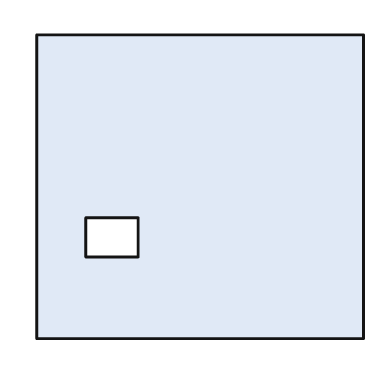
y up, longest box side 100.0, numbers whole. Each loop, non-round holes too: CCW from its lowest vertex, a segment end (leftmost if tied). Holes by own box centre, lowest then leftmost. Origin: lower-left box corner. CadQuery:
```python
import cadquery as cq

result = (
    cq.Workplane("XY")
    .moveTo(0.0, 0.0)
    .lineTo(100.0, 0.0)
    .lineTo(100.0, 93.0)
    .lineTo(0.0, 93.0)
    .close()
    .moveTo(15.0, 25.0)
    .lineTo(31.0, 25.0)
    .lineTo(31.0, 37.0)
    .lineTo(15.0, 37.0)
    .close()
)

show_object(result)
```